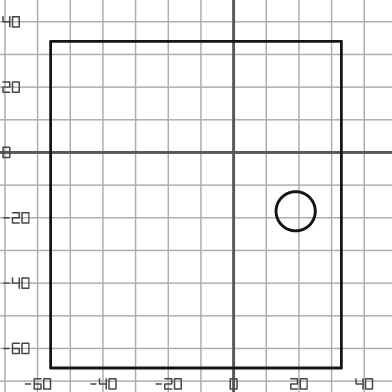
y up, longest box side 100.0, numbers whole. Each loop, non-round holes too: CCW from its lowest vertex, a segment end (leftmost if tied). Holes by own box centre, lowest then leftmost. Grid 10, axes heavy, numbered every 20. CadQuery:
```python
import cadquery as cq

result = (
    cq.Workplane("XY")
    .moveTo(-56.0, -66.0)
    .lineTo(33.0, -66.0)
    .lineTo(33.0, 34.0)
    .lineTo(-56.0, 34.0)
    .close()
    .moveTo(19.0, -18.0)
    .circle(6.0)
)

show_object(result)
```